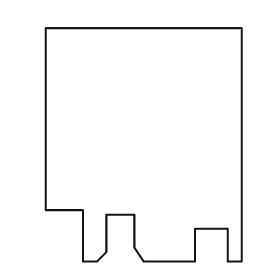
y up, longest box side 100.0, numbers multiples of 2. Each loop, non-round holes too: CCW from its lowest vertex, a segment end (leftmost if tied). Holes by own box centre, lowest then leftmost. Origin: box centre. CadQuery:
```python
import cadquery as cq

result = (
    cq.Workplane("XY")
    .moveTo(-26.0, -50.0)
    .lineTo(-20.0, -50.0)
    .lineTo(-16.0, -46.0)
    .lineTo(-16.0, -30.0)
    .lineTo(-4.0, -30.0)
    .lineTo(-4.0, -44.0)
    .lineTo(0.0, -50.0)
    .lineTo(22.0, -50.0)
    .lineTo(22.0, -36.0)
    .lineTo(36.0, -36.0)
    .lineTo(36.0, -50.0)
    .lineTo(42.0, -50.0)
    .lineTo(42.0, 50.0)
    .lineTo(-42.0, 50.0)
    .lineTo(-42.0, -28.0)
    .lineTo(-26.0, -28.0)
    .close()
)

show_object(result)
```